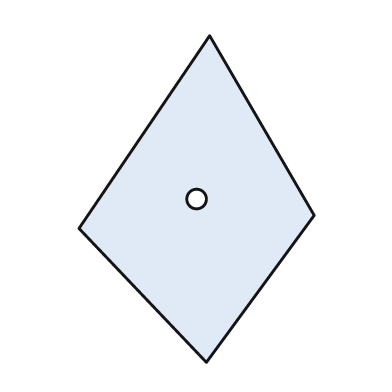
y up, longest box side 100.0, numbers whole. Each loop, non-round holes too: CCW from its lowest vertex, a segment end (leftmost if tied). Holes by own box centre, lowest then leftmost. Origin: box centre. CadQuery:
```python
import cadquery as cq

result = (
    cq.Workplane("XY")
    .moveTo(3.0, -50.0)
    .lineTo(36.0, -5.0)
    .lineTo(4.0, 50.0)
    .lineTo(-36.0, -9.0)
    .close()
    .moveTo(0.0, 0.0)
    .circle(3.0)
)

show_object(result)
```